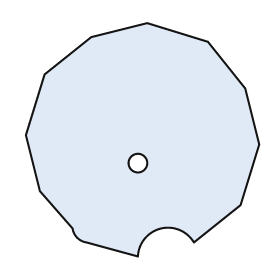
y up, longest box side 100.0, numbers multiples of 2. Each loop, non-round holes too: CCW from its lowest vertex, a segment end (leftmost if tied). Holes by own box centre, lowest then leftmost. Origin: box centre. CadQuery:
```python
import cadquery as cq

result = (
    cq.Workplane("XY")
    .moveTo(-2.0, -50.0)
    .threePointArc((8.0, -38.0), (22.0, -44.0))
    .lineTo(42.0, -28.0)
    .lineTo(50.0, -2.0)
    .lineTo(44.0, 22.0)
    .lineTo(28.0, 42.0)
    .lineTo(2.0, 50.0)
    .lineTo(-22.0, 44.0)
    .lineTo(-42.0, 28.0)
    .lineTo(-50.0, 2.0)
    .lineTo(-44.0, -22.0)
    .lineTo(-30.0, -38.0)
    .threePointArc((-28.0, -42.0), (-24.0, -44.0))
    .close()
    .moveTo(-2.0, -10.0)
    .circle(4.0)
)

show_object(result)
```